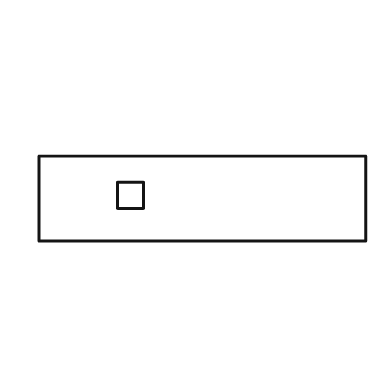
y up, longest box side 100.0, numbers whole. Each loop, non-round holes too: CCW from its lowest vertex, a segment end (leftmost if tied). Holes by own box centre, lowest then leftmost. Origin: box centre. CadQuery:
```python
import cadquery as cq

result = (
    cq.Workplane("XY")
    .moveTo(-50.0, -13.0)
    .lineTo(50.0, -13.0)
    .lineTo(50.0, 13.0)
    .lineTo(-50.0, 13.0)
    .close()
    .moveTo(-26.0, -3.0)
    .lineTo(-18.0, -3.0)
    .lineTo(-18.0, 5.0)
    .lineTo(-26.0, 5.0)
    .close()
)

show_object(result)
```